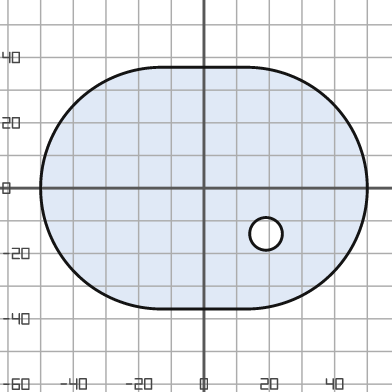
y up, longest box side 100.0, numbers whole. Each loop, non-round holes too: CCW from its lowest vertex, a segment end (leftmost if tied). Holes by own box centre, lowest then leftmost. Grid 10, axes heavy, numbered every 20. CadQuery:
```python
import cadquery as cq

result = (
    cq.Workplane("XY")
    .moveTo(-13.0, -37.0)
    .lineTo(13.0, -37.0)
    .threePointArc((50.0, 0.0), (13.0, 37.0))
    .lineTo(-13.0, 37.0)
    .threePointArc((-50.0, 0.0), (-13.0, -37.0))
    .close()
    .moveTo(19.0, -14.0)
    .circle(5.0)
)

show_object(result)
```